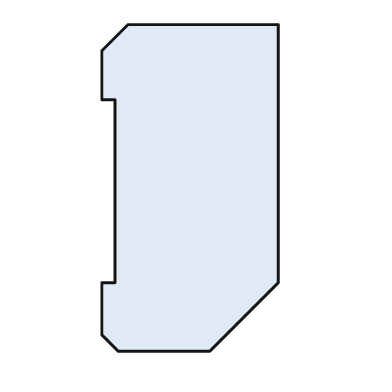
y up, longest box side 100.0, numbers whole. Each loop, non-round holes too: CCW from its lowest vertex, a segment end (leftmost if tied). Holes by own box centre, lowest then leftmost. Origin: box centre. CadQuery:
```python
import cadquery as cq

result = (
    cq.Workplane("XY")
    .moveTo(-22.0, -50.0)
    .lineTo(6.0, -50.0)
    .lineTo(27.0, -29.0)
    .lineTo(27.0, 50.0)
    .lineTo(-19.0, 50.0)
    .lineTo(-27.0, 42.0)
    .lineTo(-27.0, 27.0)
    .lineTo(-23.0, 27.0)
    .lineTo(-23.0, -29.0)
    .lineTo(-27.0, -29.0)
    .lineTo(-27.0, -45.0)
    .close()
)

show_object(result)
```